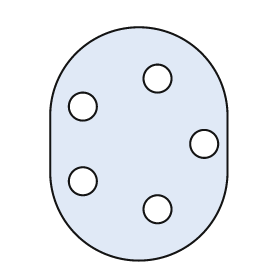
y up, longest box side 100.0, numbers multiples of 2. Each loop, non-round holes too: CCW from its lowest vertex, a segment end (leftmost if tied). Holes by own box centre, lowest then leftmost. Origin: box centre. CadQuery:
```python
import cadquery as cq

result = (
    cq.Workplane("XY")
    .moveTo(-38.0, -12.0)
    .threePointArc((0.0, -50.0), (38.0, -12.0))
    .lineTo(38.0, 12.0)
    .threePointArc((0.0, 50.0), (-38.0, 12.0))
    .close()
    .moveTo(8.0, -28.0)
    .circle(6.0)
    .moveTo(-24.0, -16.0)
    .circle(6.0)
    .moveTo(28.0, 0.0)
    .circle(6.0)
    .moveTo(-24.0, 16.0)
    .circle(6.0)
    .moveTo(8.0, 28.0)
    .circle(6.0)
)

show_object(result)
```